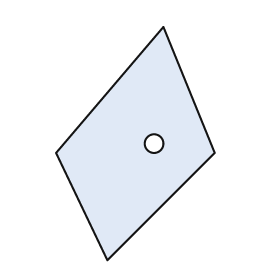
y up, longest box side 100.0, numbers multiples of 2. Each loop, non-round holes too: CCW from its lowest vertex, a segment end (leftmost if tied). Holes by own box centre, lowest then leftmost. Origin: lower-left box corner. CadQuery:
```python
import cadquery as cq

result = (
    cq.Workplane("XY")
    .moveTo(22.0, 0.0)
    .lineTo(68.0, 46.0)
    .lineTo(46.0, 100.0)
    .lineTo(0.0, 46.0)
    .close()
    .moveTo(42.0, 50.0)
    .circle(4.0)
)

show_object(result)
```